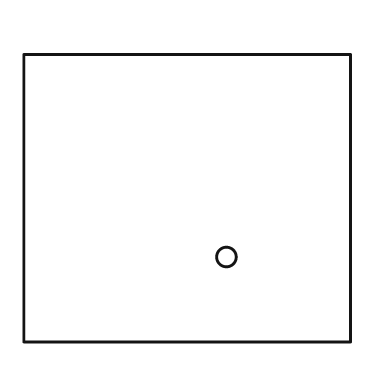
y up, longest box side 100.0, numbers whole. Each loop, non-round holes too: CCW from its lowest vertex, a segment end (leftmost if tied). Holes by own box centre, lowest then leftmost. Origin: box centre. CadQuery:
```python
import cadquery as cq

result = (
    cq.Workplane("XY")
    .moveTo(-50.0, -44.0)
    .lineTo(50.0, -44.0)
    .lineTo(50.0, 44.0)
    .lineTo(-50.0, 44.0)
    .close()
    .moveTo(12.0, -18.0)
    .circle(3.0)
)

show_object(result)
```